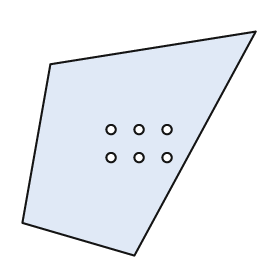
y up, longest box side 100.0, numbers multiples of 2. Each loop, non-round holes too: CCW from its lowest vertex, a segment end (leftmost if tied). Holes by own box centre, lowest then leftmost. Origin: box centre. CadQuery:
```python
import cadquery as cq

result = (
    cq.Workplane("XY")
    .moveTo(-2.0, -48.0)
    .lineTo(50.0, 48.0)
    .lineTo(-38.0, 34.0)
    .lineTo(-50.0, -34.0)
    .close()
    .moveTo(-12.0, -6.0)
    .circle(2.0)
    .moveTo(0.0, -6.0)
    .circle(2.0)
    .moveTo(12.0, -6.0)
    .circle(2.0)
    .moveTo(-12.0, 6.0)
    .circle(2.0)
    .moveTo(0.0, 6.0)
    .circle(2.0)
    .moveTo(12.0, 6.0)
    .circle(2.0)
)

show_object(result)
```